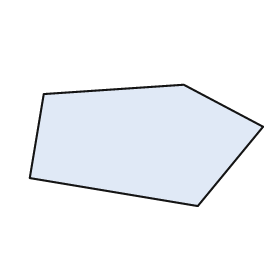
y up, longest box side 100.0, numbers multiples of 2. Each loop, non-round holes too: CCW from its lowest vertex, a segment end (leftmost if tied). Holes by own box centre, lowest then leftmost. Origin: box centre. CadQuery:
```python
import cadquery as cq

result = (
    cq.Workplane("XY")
    .moveTo(22.0, -26.0)
    .lineTo(50.0, 8.0)
    .lineTo(16.0, 26.0)
    .lineTo(-44.0, 22.0)
    .lineTo(-50.0, -14.0)
    .close()
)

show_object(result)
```